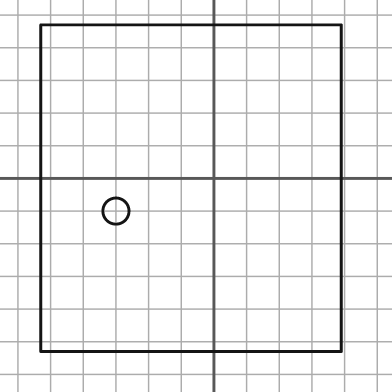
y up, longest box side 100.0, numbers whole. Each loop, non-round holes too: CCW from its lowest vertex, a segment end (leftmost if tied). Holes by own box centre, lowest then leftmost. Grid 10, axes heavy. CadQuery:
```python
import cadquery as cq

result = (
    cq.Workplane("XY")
    .moveTo(-53.0, -53.0)
    .lineTo(39.0, -53.0)
    .lineTo(39.0, 47.0)
    .lineTo(-53.0, 47.0)
    .close()
    .moveTo(-30.0, -10.0)
    .circle(4.0)
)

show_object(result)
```